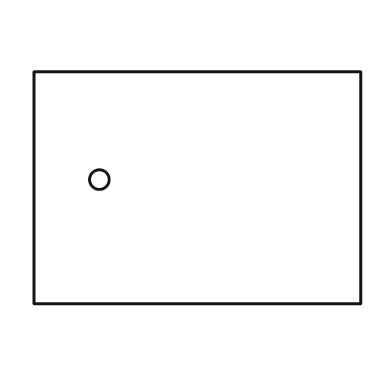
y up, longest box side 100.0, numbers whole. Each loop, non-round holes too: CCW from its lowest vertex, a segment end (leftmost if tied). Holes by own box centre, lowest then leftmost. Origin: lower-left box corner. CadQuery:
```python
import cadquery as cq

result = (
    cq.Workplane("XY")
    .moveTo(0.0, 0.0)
    .lineTo(100.0, 0.0)
    .lineTo(100.0, 71.0)
    .lineTo(0.0, 71.0)
    .close()
    .moveTo(20.0, 38.0)
    .circle(3.0)
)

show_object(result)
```